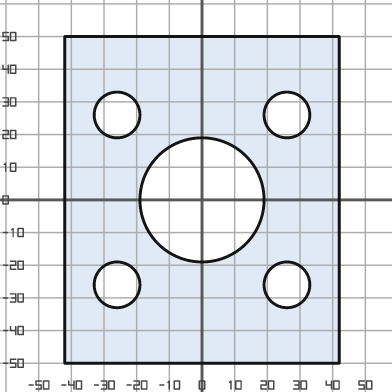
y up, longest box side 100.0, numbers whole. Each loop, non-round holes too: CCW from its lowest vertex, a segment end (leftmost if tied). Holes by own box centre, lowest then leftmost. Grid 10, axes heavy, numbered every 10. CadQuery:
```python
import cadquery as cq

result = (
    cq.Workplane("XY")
    .moveTo(-42.0, -50.0)
    .lineTo(42.0, -50.0)
    .lineTo(42.0, 50.0)
    .lineTo(-42.0, 50.0)
    .close()
    .moveTo(-26.0, -26.0)
    .circle(7.0)
    .moveTo(26.0, -26.0)
    .circle(7.0)
    .moveTo(0.0, 0.0)
    .circle(19.0)
    .moveTo(-26.0, 26.0)
    .circle(7.0)
    .moveTo(26.0, 26.0)
    .circle(7.0)
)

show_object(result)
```